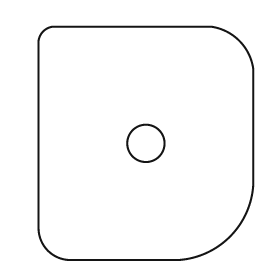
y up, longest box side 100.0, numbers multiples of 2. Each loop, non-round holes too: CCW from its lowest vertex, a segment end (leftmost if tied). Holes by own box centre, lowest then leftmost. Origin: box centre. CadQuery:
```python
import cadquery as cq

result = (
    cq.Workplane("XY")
    .moveTo(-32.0, -50.0)
    .lineTo(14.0, -50.0)
    .threePointArc((36.0, -40.0), (46.0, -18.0))
    .lineTo(46.0, 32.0)
    .threePointArc((40.0, 44.0), (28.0, 50.0))
    .lineTo(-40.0, 50.0)
    .threePointArc((-44.0, 48.0), (-46.0, 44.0))
    .lineTo(-46.0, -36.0)
    .threePointArc((-42.0, -46.0), (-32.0, -50.0))
    .close()
    .moveTo(0.0, 0.0)
    .circle(8.0)
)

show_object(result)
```